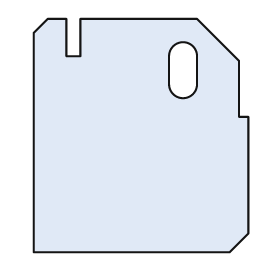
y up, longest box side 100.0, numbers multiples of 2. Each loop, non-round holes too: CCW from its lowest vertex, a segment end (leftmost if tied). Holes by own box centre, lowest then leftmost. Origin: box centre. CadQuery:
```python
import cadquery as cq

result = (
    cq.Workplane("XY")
    .moveTo(-46.0, -50.0)
    .lineTo(38.0, -50.0)
    .lineTo(46.0, -42.0)
    .lineTo(46.0, 8.0)
    .lineTo(42.0, 8.0)
    .lineTo(42.0, 32.0)
    .lineTo(24.0, 50.0)
    .lineTo(-26.0, 50.0)
    .lineTo(-26.0, 34.0)
    .lineTo(-32.0, 34.0)
    .lineTo(-32.0, 50.0)
    .lineTo(-40.0, 50.0)
    .lineTo(-46.0, 44.0)
    .close()
    .moveTo(12.0, 22.0)
    .threePointArc((18.0, 16.0), (24.0, 22.0))
    .lineTo(24.0, 34.0)
    .threePointArc((18.0, 40.0), (12.0, 34.0))
    .close()
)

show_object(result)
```